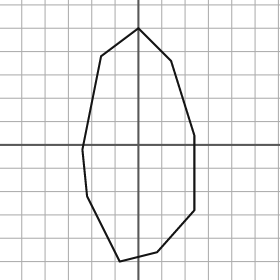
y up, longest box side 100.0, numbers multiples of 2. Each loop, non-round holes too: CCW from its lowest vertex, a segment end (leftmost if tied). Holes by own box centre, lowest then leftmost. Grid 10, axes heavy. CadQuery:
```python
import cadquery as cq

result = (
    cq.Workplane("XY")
    .moveTo(-8.0, -50.0)
    .lineTo(8.0, -46.0)
    .lineTo(24.0, -28.0)
    .lineTo(24.0, 4.0)
    .lineTo(14.0, 36.0)
    .lineTo(0.0, 50.0)
    .lineTo(-16.0, 38.0)
    .lineTo(-24.0, -2.0)
    .lineTo(-22.0, -22.0)
    .close()
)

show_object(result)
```